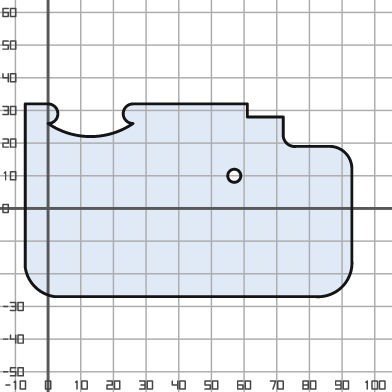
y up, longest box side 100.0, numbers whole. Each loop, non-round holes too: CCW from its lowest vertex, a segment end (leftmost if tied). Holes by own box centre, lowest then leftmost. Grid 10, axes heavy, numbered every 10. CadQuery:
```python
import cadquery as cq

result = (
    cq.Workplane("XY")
    .moveTo(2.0, -27.0)
    .lineTo(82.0, -27.0)
    .threePointArc((90.0, -24.0), (93.0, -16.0))
    .lineTo(93.0, 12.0)
    .threePointArc((91.0, 17.0), (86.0, 19.0))
    .lineTo(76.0, 19.0)
    .threePointArc((73.0, 20.0), (72.0, 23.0))
    .lineTo(72.0, 28.0)
    .lineTo(61.0, 28.0)
    .lineTo(61.0, 32.0)
    .lineTo(26.0, 32.0)
    .threePointArc((23.0, 29.0), (26.0, 26.0))
    .threePointArc((13.0, 22.0), (0.0, 26.0))
    .threePointArc((3.0, 29.0), (0.0, 32.0))
    .lineTo(-7.0, 32.0)
    .lineTo(-7.0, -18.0)
    .threePointArc((-4.0, -24.0), (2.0, -27.0))
    .close()
    .moveTo(57.0, 10.0)
    .circle(2.0)
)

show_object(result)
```